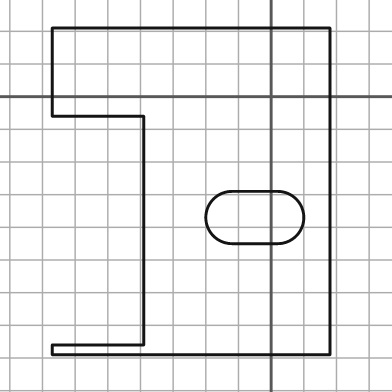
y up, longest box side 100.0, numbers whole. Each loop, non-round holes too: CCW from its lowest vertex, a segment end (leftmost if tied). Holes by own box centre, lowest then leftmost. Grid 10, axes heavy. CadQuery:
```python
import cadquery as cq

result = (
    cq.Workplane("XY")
    .moveTo(-67.0, -79.0)
    .lineTo(18.0, -79.0)
    .lineTo(18.0, 21.0)
    .lineTo(-67.0, 21.0)
    .lineTo(-67.0, -6.0)
    .lineTo(-39.0, -6.0)
    .lineTo(-39.0, -76.0)
    .lineTo(-67.0, -76.0)
    .close()
    .moveTo(-12.0, -45.0)
    .lineTo(2.0, -45.0)
    .threePointArc((10.0, -37.0), (2.0, -29.0))
    .lineTo(-12.0, -29.0)
    .threePointArc((-20.0, -37.0), (-12.0, -45.0))
    .close()
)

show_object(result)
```